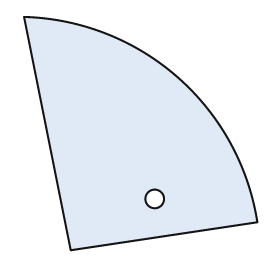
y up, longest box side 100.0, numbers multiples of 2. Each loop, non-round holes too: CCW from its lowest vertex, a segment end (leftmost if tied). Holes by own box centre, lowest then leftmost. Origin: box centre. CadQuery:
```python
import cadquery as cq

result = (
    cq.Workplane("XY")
    .moveTo(-30.0, -50.0)
    .lineTo(50.0, -38.0)
    .threePointArc((16.0, 24.0), (-50.0, 50.0))
    .close()
    .moveTo(6.0, -28.0)
    .circle(4.0)
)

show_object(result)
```